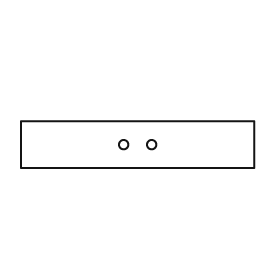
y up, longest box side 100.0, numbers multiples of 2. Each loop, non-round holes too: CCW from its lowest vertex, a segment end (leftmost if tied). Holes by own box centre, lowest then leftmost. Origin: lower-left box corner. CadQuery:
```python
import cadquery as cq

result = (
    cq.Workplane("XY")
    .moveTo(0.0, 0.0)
    .lineTo(100.0, 0.0)
    .lineTo(100.0, 20.0)
    .lineTo(0.0, 20.0)
    .close()
    .moveTo(44.0, 10.0)
    .circle(2.0)
    .moveTo(56.0, 10.0)
    .circle(2.0)
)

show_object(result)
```